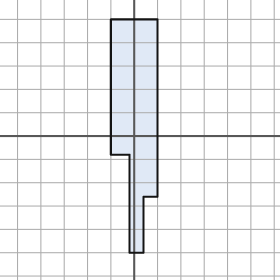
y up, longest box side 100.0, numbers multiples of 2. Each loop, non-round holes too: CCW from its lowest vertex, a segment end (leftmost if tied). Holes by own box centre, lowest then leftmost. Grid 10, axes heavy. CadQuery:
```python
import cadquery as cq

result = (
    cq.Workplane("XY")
    .moveTo(-2.0, -50.0)
    .lineTo(4.0, -50.0)
    .lineTo(4.0, -26.0)
    .lineTo(10.0, -26.0)
    .lineTo(10.0, 50.0)
    .lineTo(-10.0, 50.0)
    .lineTo(-10.0, -8.0)
    .lineTo(-2.0, -8.0)
    .close()
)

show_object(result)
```